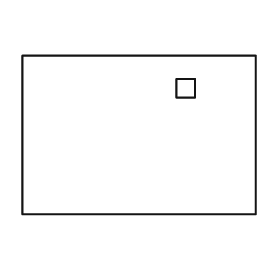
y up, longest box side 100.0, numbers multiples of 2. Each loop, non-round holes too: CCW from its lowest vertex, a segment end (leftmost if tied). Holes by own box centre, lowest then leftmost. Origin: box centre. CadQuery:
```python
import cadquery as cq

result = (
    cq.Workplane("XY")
    .moveTo(-50.0, -34.0)
    .lineTo(50.0, -34.0)
    .lineTo(50.0, 34.0)
    .lineTo(-50.0, 34.0)
    .close()
    .moveTo(16.0, 16.0)
    .lineTo(24.0, 16.0)
    .lineTo(24.0, 24.0)
    .lineTo(16.0, 24.0)
    .close()
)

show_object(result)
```